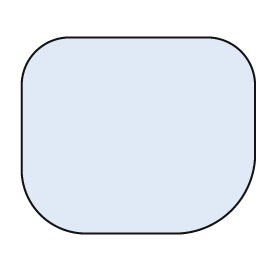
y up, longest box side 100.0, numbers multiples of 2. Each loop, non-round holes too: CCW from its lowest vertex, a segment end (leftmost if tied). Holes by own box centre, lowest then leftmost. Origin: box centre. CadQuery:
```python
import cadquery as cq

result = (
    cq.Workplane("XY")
    .moveTo(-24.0, -42.0)
    .lineTo(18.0, -42.0)
    .threePointArc((40.0, -32.0), (50.0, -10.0))
    .lineTo(50.0, 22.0)
    .threePointArc((44.0, 36.0), (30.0, 42.0))
    .lineTo(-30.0, 42.0)
    .threePointArc((-44.0, 36.0), (-50.0, 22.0))
    .lineTo(-50.0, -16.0)
    .threePointArc((-42.0, -34.0), (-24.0, -42.0))
    .close()
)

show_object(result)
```